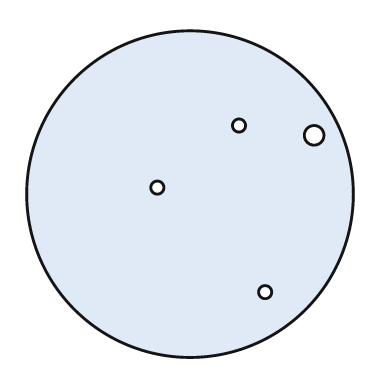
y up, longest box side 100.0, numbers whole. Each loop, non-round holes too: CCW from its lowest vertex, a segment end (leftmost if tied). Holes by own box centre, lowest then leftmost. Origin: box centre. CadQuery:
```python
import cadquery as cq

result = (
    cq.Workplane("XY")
    .moveTo(0.0, 0.0)
    .circle(50.0)
    .moveTo(23.0, -30.0)
    .circle(2.0)
    .moveTo(-10.0, 2.0)
    .circle(2.0)
    .moveTo(38.0, 18.0)
    .circle(3.0)
    .moveTo(15.0, 21.0)
    .circle(2.0)
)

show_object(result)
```